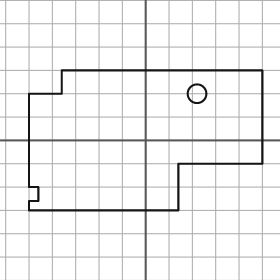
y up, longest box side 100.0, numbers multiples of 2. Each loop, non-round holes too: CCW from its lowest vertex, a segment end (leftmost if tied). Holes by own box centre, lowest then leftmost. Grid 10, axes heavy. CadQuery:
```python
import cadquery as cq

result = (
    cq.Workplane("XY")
    .moveTo(-50.0, -30.0)
    .lineTo(14.0, -30.0)
    .lineTo(14.0, -10.0)
    .lineTo(50.0, -10.0)
    .lineTo(50.0, 30.0)
    .lineTo(-36.0, 30.0)
    .lineTo(-36.0, 20.0)
    .lineTo(-50.0, 20.0)
    .lineTo(-50.0, -20.0)
    .lineTo(-46.0, -20.0)
    .lineTo(-46.0, -26.0)
    .lineTo(-50.0, -26.0)
    .close()
    .moveTo(22.0, 20.0)
    .circle(4.0)
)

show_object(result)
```